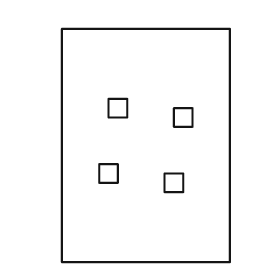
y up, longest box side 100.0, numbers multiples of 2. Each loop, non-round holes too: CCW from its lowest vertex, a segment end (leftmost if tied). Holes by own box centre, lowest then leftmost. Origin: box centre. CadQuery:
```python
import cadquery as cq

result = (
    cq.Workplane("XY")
    .moveTo(-36.0, -50.0)
    .lineTo(36.0, -50.0)
    .lineTo(36.0, 50.0)
    .lineTo(-36.0, 50.0)
    .close()
    .moveTo(8.0, -20.0)
    .lineTo(16.0, -20.0)
    .lineTo(16.0, -12.0)
    .lineTo(8.0, -12.0)
    .close()
    .moveTo(-20.0, -16.0)
    .lineTo(-12.0, -16.0)
    .lineTo(-12.0, -8.0)
    .lineTo(-20.0, -8.0)
    .close()
    .moveTo(12.0, 8.0)
    .lineTo(20.0, 8.0)
    .lineTo(20.0, 16.0)
    .lineTo(12.0, 16.0)
    .close()
    .moveTo(-16.0, 12.0)
    .lineTo(-8.0, 12.0)
    .lineTo(-8.0, 20.0)
    .lineTo(-16.0, 20.0)
    .close()
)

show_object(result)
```